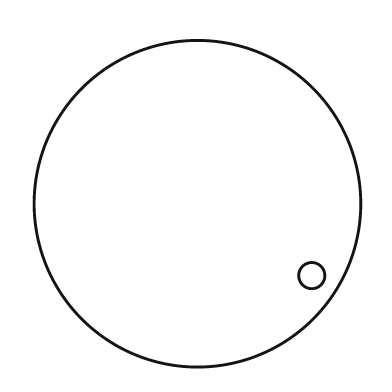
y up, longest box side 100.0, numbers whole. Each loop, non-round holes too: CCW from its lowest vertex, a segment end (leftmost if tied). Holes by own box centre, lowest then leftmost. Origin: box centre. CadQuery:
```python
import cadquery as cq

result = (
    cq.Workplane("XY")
    .moveTo(0.0, 0.0)
    .circle(50.0)
    .moveTo(35.0, -22.0)
    .circle(4.0)
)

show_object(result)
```